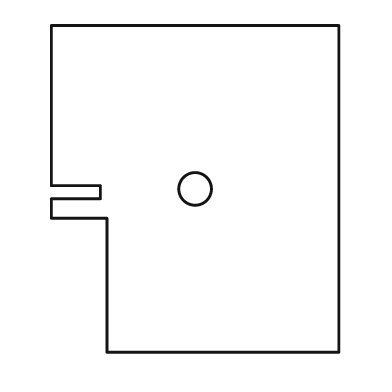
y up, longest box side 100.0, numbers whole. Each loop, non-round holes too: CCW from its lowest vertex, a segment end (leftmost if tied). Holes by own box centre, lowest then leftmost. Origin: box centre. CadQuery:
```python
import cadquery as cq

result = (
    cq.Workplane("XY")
    .moveTo(-27.0, -50.0)
    .lineTo(44.0, -50.0)
    .lineTo(44.0, 50.0)
    .lineTo(-44.0, 50.0)
    .lineTo(-44.0, 1.0)
    .lineTo(-29.0, 1.0)
    .lineTo(-29.0, -3.0)
    .lineTo(-44.0, -3.0)
    .lineTo(-44.0, -9.0)
    .lineTo(-27.0, -9.0)
    .close()
    .moveTo(0.0, 0.0)
    .circle(5.0)
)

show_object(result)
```